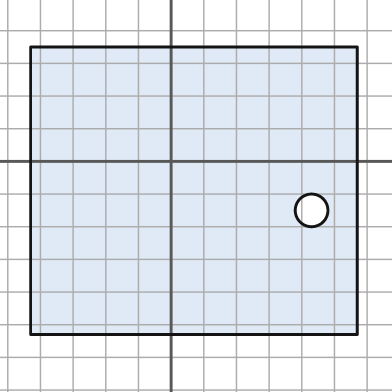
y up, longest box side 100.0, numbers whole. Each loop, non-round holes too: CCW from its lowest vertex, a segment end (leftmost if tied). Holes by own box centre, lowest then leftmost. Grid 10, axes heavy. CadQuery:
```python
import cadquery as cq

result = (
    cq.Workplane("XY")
    .moveTo(-43.0, -53.0)
    .lineTo(57.0, -53.0)
    .lineTo(57.0, 35.0)
    .lineTo(-43.0, 35.0)
    .close()
    .moveTo(43.0, -15.0)
    .circle(5.0)
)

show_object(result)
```